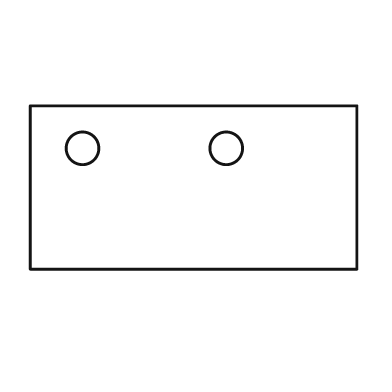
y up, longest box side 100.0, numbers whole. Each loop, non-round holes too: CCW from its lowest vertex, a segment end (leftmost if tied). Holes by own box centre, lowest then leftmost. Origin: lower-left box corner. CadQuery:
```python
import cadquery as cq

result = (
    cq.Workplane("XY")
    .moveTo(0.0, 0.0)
    .lineTo(100.0, 0.0)
    .lineTo(100.0, 50.0)
    .lineTo(0.0, 50.0)
    .close()
    .moveTo(16.0, 37.0)
    .circle(5.0)
    .moveTo(60.0, 37.0)
    .circle(5.0)
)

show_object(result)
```